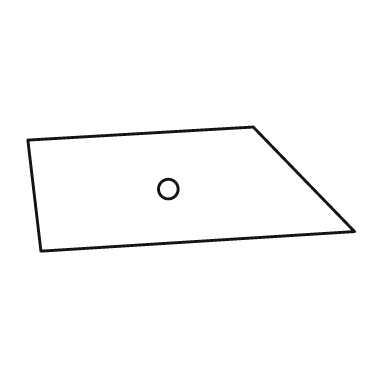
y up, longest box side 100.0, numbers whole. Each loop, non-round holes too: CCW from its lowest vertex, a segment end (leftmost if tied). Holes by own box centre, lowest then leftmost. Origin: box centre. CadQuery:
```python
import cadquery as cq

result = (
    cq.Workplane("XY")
    .moveTo(-46.0, -19.0)
    .lineTo(50.0, -13.0)
    .lineTo(19.0, 19.0)
    .lineTo(-50.0, 15.0)
    .close()
    .moveTo(-7.0, 0.0)
    .circle(3.0)
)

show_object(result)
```